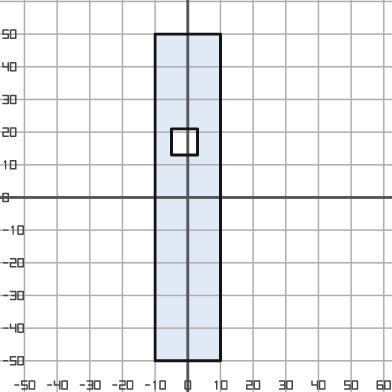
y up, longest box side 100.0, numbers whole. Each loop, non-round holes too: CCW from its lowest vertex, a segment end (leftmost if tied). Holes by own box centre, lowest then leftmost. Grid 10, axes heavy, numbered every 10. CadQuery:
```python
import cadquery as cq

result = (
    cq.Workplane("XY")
    .moveTo(-10.0, -50.0)
    .lineTo(10.0, -50.0)
    .lineTo(10.0, 50.0)
    .lineTo(-10.0, 50.0)
    .close()
    .moveTo(-5.0, 13.0)
    .lineTo(3.0, 13.0)
    .lineTo(3.0, 21.0)
    .lineTo(-5.0, 21.0)
    .close()
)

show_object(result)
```